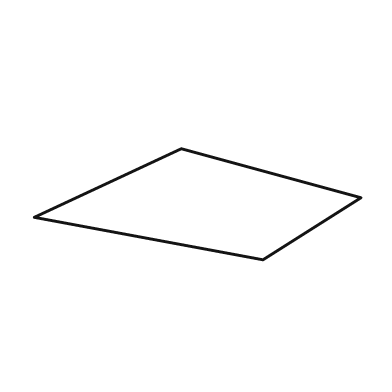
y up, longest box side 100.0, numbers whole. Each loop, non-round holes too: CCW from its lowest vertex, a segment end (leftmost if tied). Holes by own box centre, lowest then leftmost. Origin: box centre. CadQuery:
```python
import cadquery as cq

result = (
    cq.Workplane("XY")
    .moveTo(20.0, -17.0)
    .lineTo(50.0, 2.0)
    .lineTo(-5.0, 17.0)
    .lineTo(-50.0, -4.0)
    .close()
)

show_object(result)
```